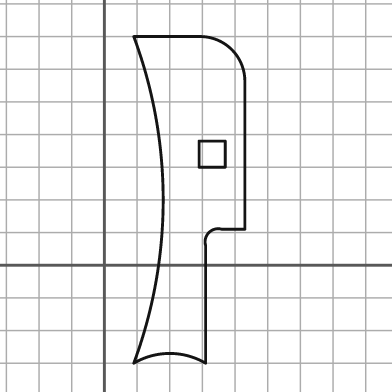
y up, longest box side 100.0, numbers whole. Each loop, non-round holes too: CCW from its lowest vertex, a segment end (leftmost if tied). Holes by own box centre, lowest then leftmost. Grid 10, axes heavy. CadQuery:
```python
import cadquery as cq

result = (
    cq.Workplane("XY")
    .moveTo(9.0, -30.0)
    .threePointArc((20.0, -27.0), (31.0, -30.0))
    .lineTo(31.0, 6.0)
    .threePointArc((32.0, 10.0), (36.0, 11.0))
    .lineTo(43.0, 11.0)
    .lineTo(43.0, 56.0)
    .threePointArc((39.0, 66.0), (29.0, 70.0))
    .lineTo(9.0, 70.0)
    .threePointArc((18.0, 20.0), (9.0, -30.0))
    .close()
    .moveTo(29.0, 30.0)
    .lineTo(37.0, 30.0)
    .lineTo(37.0, 38.0)
    .lineTo(29.0, 38.0)
    .close()
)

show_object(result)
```